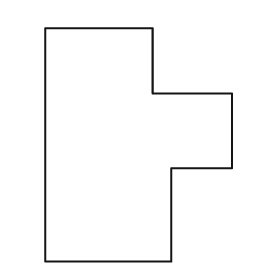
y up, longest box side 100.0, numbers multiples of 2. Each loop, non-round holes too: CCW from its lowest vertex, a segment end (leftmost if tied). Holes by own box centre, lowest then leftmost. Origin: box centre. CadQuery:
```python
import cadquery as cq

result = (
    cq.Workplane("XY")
    .moveTo(-40.0, -50.0)
    .lineTo(14.0, -50.0)
    .lineTo(14.0, -10.0)
    .lineTo(40.0, -10.0)
    .lineTo(40.0, 22.0)
    .lineTo(6.0, 22.0)
    .lineTo(6.0, 50.0)
    .lineTo(-40.0, 50.0)
    .close()
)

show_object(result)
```